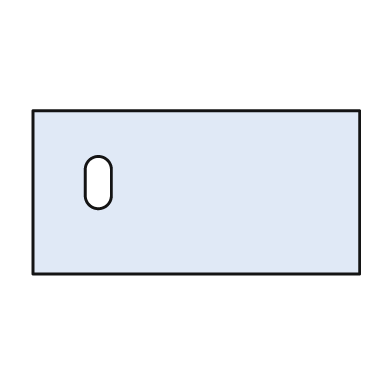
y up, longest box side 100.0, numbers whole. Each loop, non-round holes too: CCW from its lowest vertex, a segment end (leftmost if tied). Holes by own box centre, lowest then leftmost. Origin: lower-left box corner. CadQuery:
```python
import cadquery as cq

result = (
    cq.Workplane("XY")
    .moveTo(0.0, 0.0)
    .lineTo(100.0, 0.0)
    .lineTo(100.0, 50.0)
    .lineTo(0.0, 50.0)
    .close()
    .moveTo(16.0, 24.0)
    .threePointArc((20.0, 20.0), (24.0, 24.0))
    .lineTo(24.0, 32.0)
    .threePointArc((20.0, 36.0), (16.0, 32.0))
    .close()
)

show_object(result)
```